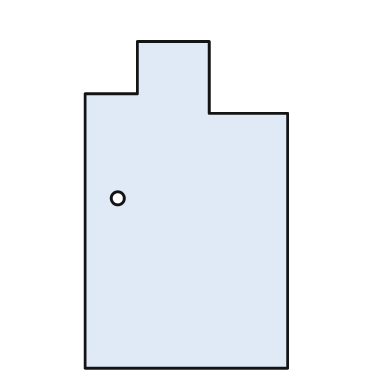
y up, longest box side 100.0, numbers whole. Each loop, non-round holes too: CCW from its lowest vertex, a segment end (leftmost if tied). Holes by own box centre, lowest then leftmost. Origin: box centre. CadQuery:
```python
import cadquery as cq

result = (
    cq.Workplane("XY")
    .moveTo(-31.0, -50.0)
    .lineTo(31.0, -50.0)
    .lineTo(31.0, 28.0)
    .lineTo(7.0, 28.0)
    .lineTo(7.0, 50.0)
    .lineTo(-15.0, 50.0)
    .lineTo(-15.0, 34.0)
    .lineTo(-31.0, 34.0)
    .close()
    .moveTo(-21.0, 2.0)
    .circle(2.0)
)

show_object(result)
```